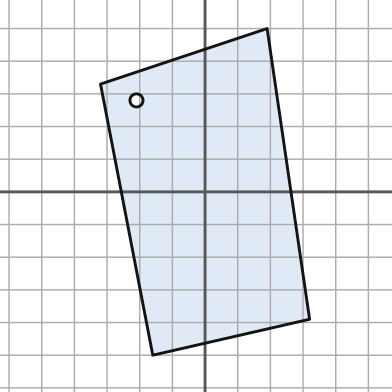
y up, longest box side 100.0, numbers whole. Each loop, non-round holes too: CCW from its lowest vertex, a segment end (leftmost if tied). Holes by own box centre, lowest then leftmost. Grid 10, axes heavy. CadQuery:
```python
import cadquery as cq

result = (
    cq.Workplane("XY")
    .moveTo(-16.0, -50.0)
    .lineTo(32.0, -39.0)
    .lineTo(19.0, 50.0)
    .lineTo(-32.0, 33.0)
    .close()
    .moveTo(-21.0, 28.0)
    .circle(2.0)
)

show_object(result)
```